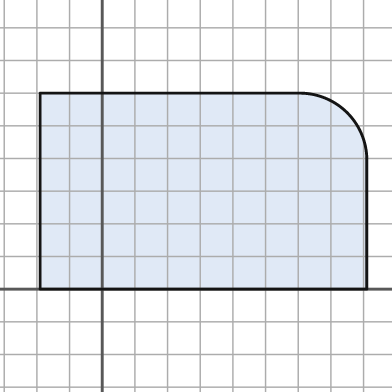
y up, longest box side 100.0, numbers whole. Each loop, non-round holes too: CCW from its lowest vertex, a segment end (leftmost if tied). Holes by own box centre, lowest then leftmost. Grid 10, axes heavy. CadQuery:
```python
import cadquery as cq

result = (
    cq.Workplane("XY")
    .moveTo(-19.0, 0.0)
    .lineTo(81.0, 0.0)
    .lineTo(81.0, 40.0)
    .threePointArc((75.0, 54.0), (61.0, 60.0))
    .lineTo(-19.0, 60.0)
    .close()
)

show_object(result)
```